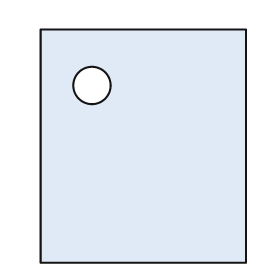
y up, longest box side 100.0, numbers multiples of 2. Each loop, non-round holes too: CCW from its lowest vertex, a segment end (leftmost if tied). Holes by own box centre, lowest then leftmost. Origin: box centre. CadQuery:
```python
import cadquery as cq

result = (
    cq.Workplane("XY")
    .moveTo(-44.0, -50.0)
    .lineTo(44.0, -50.0)
    .lineTo(44.0, 50.0)
    .lineTo(-44.0, 50.0)
    .close()
    .moveTo(-22.0, 26.0)
    .circle(8.0)
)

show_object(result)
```